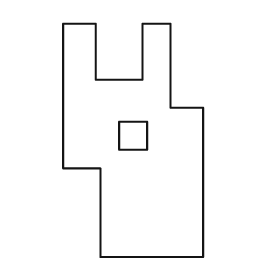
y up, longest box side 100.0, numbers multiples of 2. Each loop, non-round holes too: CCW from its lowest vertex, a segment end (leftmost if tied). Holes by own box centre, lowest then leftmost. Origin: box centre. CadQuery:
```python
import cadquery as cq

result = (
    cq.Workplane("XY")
    .moveTo(-14.0, -50.0)
    .lineTo(30.0, -50.0)
    .lineTo(30.0, 14.0)
    .lineTo(16.0, 14.0)
    .lineTo(16.0, 50.0)
    .lineTo(4.0, 50.0)
    .lineTo(4.0, 26.0)
    .lineTo(-16.0, 26.0)
    .lineTo(-16.0, 50.0)
    .lineTo(-30.0, 50.0)
    .lineTo(-30.0, -12.0)
    .lineTo(-14.0, -12.0)
    .close()
    .moveTo(-6.0, -4.0)
    .lineTo(6.0, -4.0)
    .lineTo(6.0, 8.0)
    .lineTo(-6.0, 8.0)
    .close()
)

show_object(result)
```